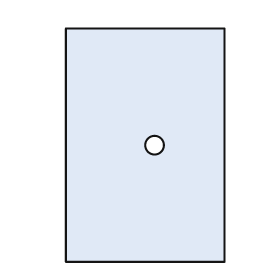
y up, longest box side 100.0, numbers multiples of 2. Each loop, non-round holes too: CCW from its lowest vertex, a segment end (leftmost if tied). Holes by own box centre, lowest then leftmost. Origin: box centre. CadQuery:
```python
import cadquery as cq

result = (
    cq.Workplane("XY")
    .moveTo(-34.0, -50.0)
    .lineTo(34.0, -50.0)
    .lineTo(34.0, 50.0)
    .lineTo(-34.0, 50.0)
    .close()
    .moveTo(4.0, 0.0)
    .circle(4.0)
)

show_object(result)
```